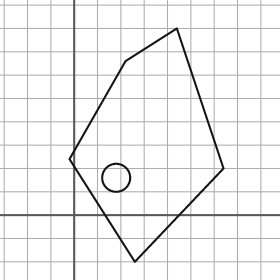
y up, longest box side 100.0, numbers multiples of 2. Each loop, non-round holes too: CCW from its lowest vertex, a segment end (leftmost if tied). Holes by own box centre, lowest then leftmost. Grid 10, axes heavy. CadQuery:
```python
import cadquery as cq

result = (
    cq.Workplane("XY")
    .moveTo(26.0, -20.0)
    .lineTo(64.0, 20.0)
    .lineTo(44.0, 80.0)
    .lineTo(22.0, 66.0)
    .lineTo(-2.0, 24.0)
    .close()
    .moveTo(18.0, 16.0)
    .circle(6.0)
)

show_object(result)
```